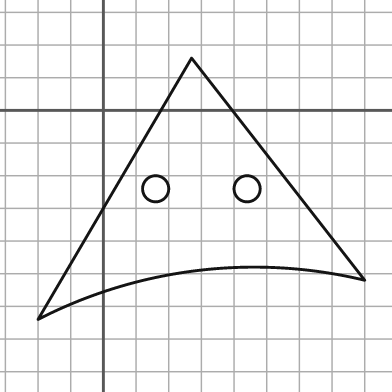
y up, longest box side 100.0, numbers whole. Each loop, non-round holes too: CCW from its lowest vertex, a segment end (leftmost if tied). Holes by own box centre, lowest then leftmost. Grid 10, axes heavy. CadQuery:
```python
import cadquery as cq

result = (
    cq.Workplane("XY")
    .moveTo(-20.0, -64.0)
    .threePointArc((29.0, -49.0), (80.0, -52.0))
    .lineTo(27.0, 16.0)
    .close()
    .moveTo(16.0, -24.0)
    .circle(4.0)
    .moveTo(44.0, -24.0)
    .circle(4.0)
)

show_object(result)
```